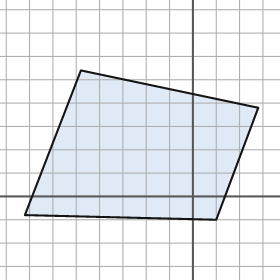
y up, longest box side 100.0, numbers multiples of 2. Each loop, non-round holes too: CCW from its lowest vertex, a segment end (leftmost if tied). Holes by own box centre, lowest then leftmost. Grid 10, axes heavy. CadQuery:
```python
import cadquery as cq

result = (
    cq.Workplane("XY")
    .moveTo(10.0, -10.0)
    .lineTo(28.0, 38.0)
    .lineTo(-48.0, 54.0)
    .lineTo(-72.0, -8.0)
    .close()
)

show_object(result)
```